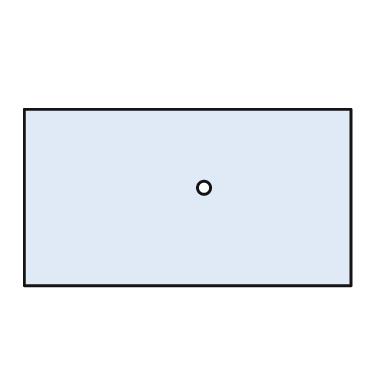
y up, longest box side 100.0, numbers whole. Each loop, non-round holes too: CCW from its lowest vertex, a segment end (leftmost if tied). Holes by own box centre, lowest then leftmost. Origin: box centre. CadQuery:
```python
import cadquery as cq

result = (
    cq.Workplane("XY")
    .moveTo(-50.0, -27.0)
    .lineTo(50.0, -27.0)
    .lineTo(50.0, 27.0)
    .lineTo(-50.0, 27.0)
    .close()
    .moveTo(5.0, 3.0)
    .circle(2.0)
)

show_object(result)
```